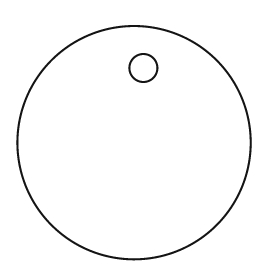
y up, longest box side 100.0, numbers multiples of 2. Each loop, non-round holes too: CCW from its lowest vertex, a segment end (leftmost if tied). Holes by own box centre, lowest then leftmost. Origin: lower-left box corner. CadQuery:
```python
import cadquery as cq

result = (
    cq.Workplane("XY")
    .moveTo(50.0, 50.0)
    .circle(50.0)
    .moveTo(54.0, 82.0)
    .circle(6.0)
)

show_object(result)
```